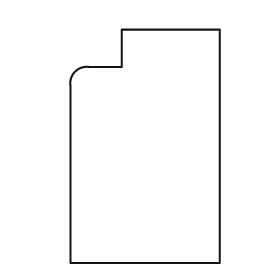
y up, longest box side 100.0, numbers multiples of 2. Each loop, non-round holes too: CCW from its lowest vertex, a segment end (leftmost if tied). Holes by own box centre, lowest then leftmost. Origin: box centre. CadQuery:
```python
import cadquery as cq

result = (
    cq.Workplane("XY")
    .moveTo(-32.0, -50.0)
    .lineTo(32.0, -50.0)
    .lineTo(32.0, 50.0)
    .lineTo(-10.0, 50.0)
    .lineTo(-10.0, 34.0)
    .lineTo(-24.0, 34.0)
    .threePointArc((-30.0, 32.0), (-32.0, 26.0))
    .close()
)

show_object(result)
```